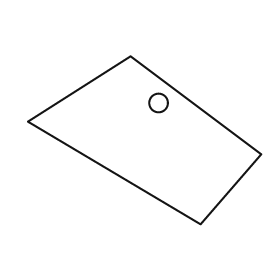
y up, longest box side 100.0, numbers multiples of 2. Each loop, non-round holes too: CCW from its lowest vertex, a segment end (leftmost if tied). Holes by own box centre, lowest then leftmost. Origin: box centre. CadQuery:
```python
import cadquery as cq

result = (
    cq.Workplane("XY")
    .moveTo(24.0, -36.0)
    .lineTo(50.0, -6.0)
    .lineTo(-6.0, 36.0)
    .lineTo(-50.0, 8.0)
    .close()
    .moveTo(6.0, 16.0)
    .circle(4.0)
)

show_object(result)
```